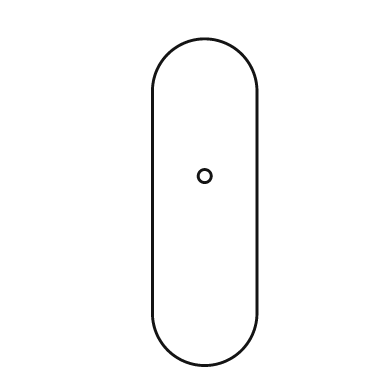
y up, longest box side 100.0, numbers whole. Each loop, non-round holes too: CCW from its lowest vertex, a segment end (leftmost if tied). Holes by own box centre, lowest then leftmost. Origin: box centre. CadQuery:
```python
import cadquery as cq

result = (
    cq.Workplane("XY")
    .moveTo(-16.0, -34.0)
    .threePointArc((0.0, -50.0), (16.0, -34.0))
    .lineTo(16.0, 34.0)
    .threePointArc((0.0, 50.0), (-16.0, 34.0))
    .close()
    .moveTo(0.0, 8.0)
    .circle(2.0)
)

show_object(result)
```